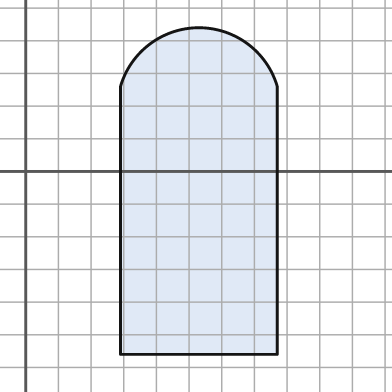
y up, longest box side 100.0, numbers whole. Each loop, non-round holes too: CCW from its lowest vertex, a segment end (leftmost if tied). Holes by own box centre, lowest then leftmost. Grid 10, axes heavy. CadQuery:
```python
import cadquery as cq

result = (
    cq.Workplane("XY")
    .moveTo(29.0, -56.0)
    .lineTo(77.0, -56.0)
    .lineTo(77.0, 26.0)
    .threePointArc((53.0, 44.0), (29.0, 26.0))
    .close()
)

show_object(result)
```